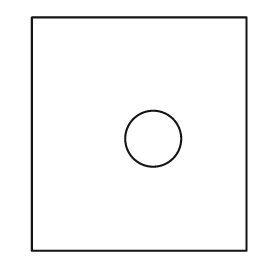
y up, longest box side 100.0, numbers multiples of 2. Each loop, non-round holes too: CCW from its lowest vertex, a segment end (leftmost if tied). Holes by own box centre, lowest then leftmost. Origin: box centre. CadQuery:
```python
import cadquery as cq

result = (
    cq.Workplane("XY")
    .moveTo(-46.0, -50.0)
    .lineTo(46.0, -50.0)
    .lineTo(46.0, 50.0)
    .lineTo(-46.0, 50.0)
    .close()
    .moveTo(6.0, -2.0)
    .circle(12.0)
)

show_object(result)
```